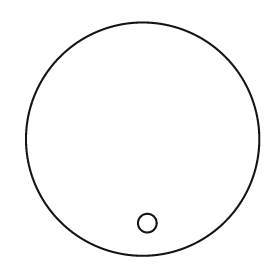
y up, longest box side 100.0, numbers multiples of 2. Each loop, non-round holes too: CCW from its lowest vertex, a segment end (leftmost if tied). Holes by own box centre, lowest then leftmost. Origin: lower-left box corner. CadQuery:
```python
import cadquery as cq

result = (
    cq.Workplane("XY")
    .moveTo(50.0, 50.0)
    .circle(50.0)
    .moveTo(52.0, 14.0)
    .circle(4.0)
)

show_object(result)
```